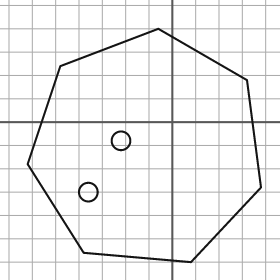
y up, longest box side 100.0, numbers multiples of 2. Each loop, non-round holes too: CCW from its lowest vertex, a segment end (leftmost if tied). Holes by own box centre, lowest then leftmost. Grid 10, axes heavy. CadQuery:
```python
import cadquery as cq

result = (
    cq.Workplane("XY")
    .moveTo(8.0, -60.0)
    .lineTo(38.0, -28.0)
    .lineTo(32.0, 18.0)
    .lineTo(-6.0, 40.0)
    .lineTo(-48.0, 24.0)
    .lineTo(-62.0, -18.0)
    .lineTo(-38.0, -56.0)
    .close()
    .moveTo(-36.0, -30.0)
    .circle(4.0)
    .moveTo(-22.0, -8.0)
    .circle(4.0)
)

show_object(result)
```